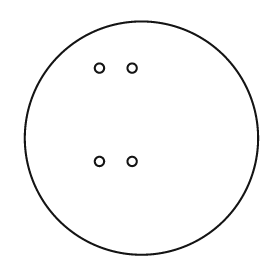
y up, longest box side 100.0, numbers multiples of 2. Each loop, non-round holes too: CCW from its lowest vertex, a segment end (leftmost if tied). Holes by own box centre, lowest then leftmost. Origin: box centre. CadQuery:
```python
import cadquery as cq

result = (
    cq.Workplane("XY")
    .moveTo(0.0, 0.0)
    .circle(50.0)
    .moveTo(-18.0, -10.0)
    .circle(2.0)
    .moveTo(-4.0, -10.0)
    .circle(2.0)
    .moveTo(-18.0, 30.0)
    .circle(2.0)
    .moveTo(-4.0, 30.0)
    .circle(2.0)
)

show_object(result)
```